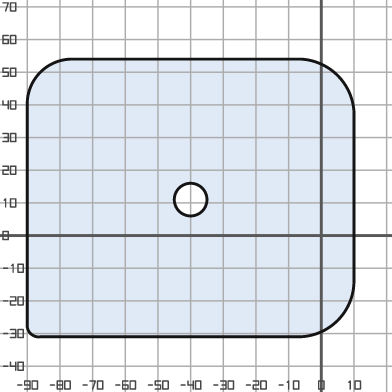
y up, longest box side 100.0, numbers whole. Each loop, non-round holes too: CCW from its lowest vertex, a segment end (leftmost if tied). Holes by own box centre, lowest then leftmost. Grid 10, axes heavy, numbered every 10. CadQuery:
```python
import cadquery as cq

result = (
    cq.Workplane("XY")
    .moveTo(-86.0, -31.0)
    .lineTo(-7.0, -31.0)
    .threePointArc((5.0, -26.0), (10.0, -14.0))
    .lineTo(10.0, 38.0)
    .threePointArc((5.0, 49.0), (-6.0, 54.0))
    .lineTo(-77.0, 54.0)
    .threePointArc((-86.0, 50.0), (-90.0, 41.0))
    .lineTo(-90.0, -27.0)
    .threePointArc((-89.0, -30.0), (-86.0, -31.0))
    .close()
    .moveTo(-40.0, 11.0)
    .circle(5.0)
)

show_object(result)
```